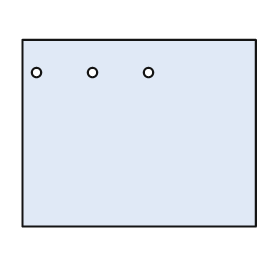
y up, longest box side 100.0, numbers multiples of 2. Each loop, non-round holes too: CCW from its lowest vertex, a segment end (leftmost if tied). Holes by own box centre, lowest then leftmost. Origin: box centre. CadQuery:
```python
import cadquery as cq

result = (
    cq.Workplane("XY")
    .moveTo(-50.0, -40.0)
    .lineTo(50.0, -40.0)
    .lineTo(50.0, 40.0)
    .lineTo(-50.0, 40.0)
    .close()
    .moveTo(-44.0, 26.0)
    .circle(2.0)
    .moveTo(-20.0, 26.0)
    .circle(2.0)
    .moveTo(4.0, 26.0)
    .circle(2.0)
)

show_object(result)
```